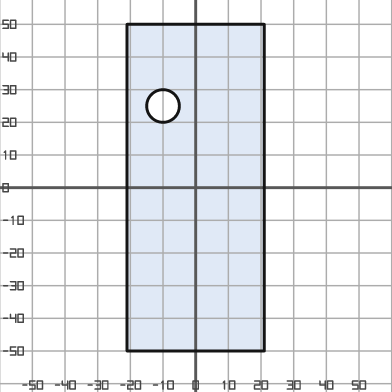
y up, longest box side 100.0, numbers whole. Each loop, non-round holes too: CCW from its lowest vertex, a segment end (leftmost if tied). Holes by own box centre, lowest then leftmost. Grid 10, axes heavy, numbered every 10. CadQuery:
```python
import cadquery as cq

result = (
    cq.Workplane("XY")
    .moveTo(-21.0, -50.0)
    .lineTo(21.0, -50.0)
    .lineTo(21.0, 50.0)
    .lineTo(-21.0, 50.0)
    .close()
    .moveTo(-10.0, 25.0)
    .circle(5.0)
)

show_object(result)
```